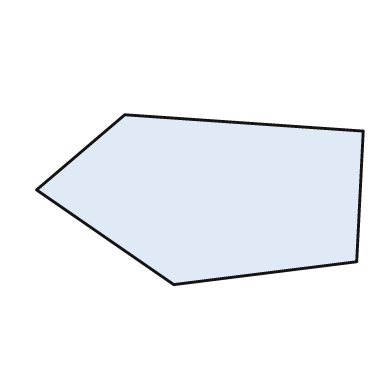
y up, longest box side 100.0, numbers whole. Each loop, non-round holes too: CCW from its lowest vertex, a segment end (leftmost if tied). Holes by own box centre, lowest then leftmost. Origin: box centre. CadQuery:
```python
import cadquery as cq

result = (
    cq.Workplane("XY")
    .moveTo(-8.0, -26.0)
    .lineTo(48.0, -19.0)
    .lineTo(50.0, 21.0)
    .lineTo(-23.0, 26.0)
    .lineTo(-50.0, 3.0)
    .close()
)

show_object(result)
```